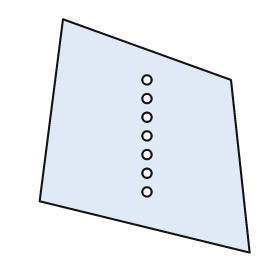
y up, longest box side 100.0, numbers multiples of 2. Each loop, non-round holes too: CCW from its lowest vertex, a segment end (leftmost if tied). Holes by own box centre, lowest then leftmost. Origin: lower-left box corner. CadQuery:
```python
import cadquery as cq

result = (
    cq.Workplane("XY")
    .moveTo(90.0, 0.0)
    .lineTo(82.0, 74.0)
    .lineTo(10.0, 100.0)
    .lineTo(0.0, 22.0)
    .close()
    .moveTo(46.0, 26.0)
    .circle(2.0)
    .moveTo(46.0, 34.0)
    .circle(2.0)
    .moveTo(46.0, 42.0)
    .circle(2.0)
    .moveTo(46.0, 50.0)
    .circle(2.0)
    .moveTo(46.0, 58.0)
    .circle(2.0)
    .moveTo(46.0, 66.0)
    .circle(2.0)
    .moveTo(46.0, 74.0)
    .circle(2.0)
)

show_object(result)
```